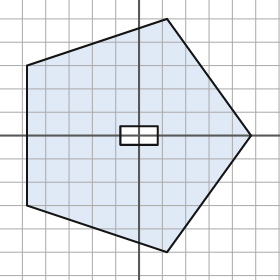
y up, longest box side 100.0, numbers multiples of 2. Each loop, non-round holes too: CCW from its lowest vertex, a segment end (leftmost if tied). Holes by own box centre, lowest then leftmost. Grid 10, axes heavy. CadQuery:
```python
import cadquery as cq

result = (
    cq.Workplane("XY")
    .moveTo(12.0, -50.0)
    .lineTo(48.0, 0.0)
    .lineTo(12.0, 50.0)
    .lineTo(-48.0, 30.0)
    .lineTo(-48.0, -30.0)
    .close()
    .moveTo(-8.0, -4.0)
    .lineTo(8.0, -4.0)
    .lineTo(8.0, 4.0)
    .lineTo(-8.0, 4.0)
    .close()
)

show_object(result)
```